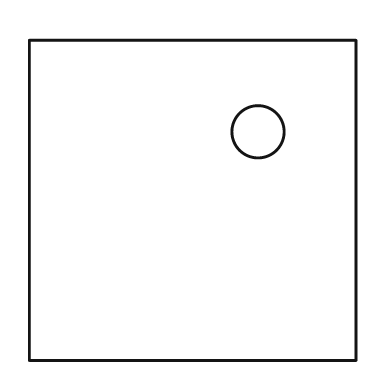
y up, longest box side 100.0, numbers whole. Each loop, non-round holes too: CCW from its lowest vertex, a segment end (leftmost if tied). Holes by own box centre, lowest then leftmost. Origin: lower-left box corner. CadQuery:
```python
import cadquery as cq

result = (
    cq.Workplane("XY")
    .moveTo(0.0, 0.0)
    .lineTo(100.0, 0.0)
    .lineTo(100.0, 98.0)
    .lineTo(0.0, 98.0)
    .close()
    .moveTo(70.0, 70.0)
    .circle(8.0)
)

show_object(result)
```